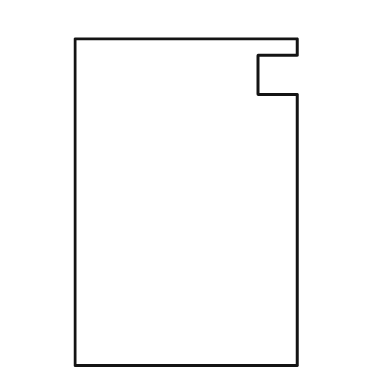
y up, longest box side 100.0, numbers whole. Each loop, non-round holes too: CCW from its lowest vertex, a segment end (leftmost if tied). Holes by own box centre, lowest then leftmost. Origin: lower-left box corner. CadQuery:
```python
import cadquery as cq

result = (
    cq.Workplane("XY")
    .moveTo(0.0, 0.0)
    .lineTo(68.0, 0.0)
    .lineTo(68.0, 83.0)
    .lineTo(56.0, 83.0)
    .lineTo(56.0, 95.0)
    .lineTo(68.0, 95.0)
    .lineTo(68.0, 100.0)
    .lineTo(0.0, 100.0)
    .close()
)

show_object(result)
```